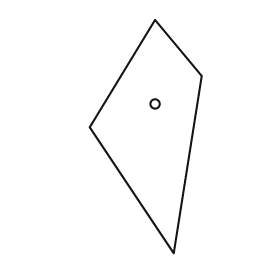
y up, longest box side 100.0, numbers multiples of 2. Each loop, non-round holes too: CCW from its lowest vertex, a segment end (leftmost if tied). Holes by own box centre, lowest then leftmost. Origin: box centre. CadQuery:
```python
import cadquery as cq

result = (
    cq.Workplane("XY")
    .moveTo(12.0, -50.0)
    .lineTo(24.0, 26.0)
    .lineTo(4.0, 50.0)
    .lineTo(-24.0, 4.0)
    .close()
    .moveTo(4.0, 14.0)
    .circle(2.0)
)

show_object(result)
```